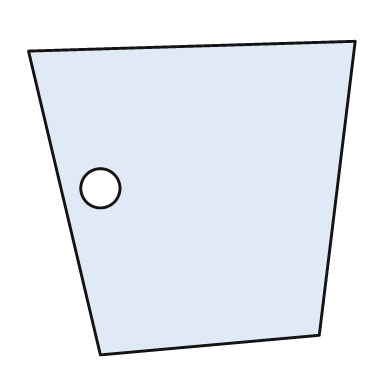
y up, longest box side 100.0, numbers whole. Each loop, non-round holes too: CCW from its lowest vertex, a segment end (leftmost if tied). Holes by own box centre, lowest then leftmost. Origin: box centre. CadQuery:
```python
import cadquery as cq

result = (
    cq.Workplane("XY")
    .moveTo(-28.0, -48.0)
    .lineTo(39.0, -42.0)
    .lineTo(50.0, 48.0)
    .lineTo(-50.0, 45.0)
    .close()
    .moveTo(-28.0, 3.0)
    .circle(6.0)
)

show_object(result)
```